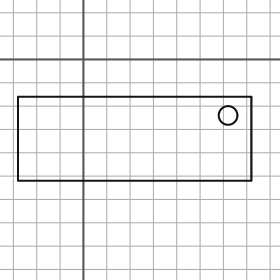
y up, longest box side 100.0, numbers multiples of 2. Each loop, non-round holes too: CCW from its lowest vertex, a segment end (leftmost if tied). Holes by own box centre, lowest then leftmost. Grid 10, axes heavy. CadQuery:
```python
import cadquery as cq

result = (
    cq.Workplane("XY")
    .moveTo(-28.0, -52.0)
    .lineTo(72.0, -52.0)
    .lineTo(72.0, -16.0)
    .lineTo(-28.0, -16.0)
    .close()
    .moveTo(62.0, -24.0)
    .circle(4.0)
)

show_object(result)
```